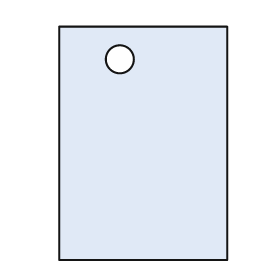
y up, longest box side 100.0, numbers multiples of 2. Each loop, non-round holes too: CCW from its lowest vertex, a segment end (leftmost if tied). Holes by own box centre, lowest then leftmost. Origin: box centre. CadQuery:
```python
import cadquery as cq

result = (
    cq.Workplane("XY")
    .moveTo(-36.0, -50.0)
    .lineTo(36.0, -50.0)
    .lineTo(36.0, 50.0)
    .lineTo(-36.0, 50.0)
    .close()
    .moveTo(-10.0, 36.0)
    .circle(6.0)
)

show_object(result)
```